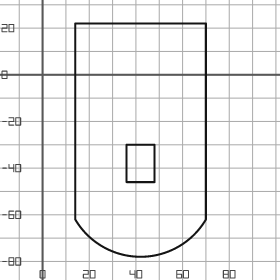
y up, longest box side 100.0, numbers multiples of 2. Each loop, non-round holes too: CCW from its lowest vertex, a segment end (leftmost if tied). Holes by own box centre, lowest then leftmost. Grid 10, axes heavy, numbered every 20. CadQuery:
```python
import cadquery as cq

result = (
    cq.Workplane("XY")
    .moveTo(14.0, -62.0)
    .threePointArc((42.0, -78.0), (70.0, -62.0))
    .lineTo(70.0, 22.0)
    .lineTo(14.0, 22.0)
    .close()
    .moveTo(36.0, -46.0)
    .lineTo(48.0, -46.0)
    .lineTo(48.0, -30.0)
    .lineTo(36.0, -30.0)
    .close()
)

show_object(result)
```